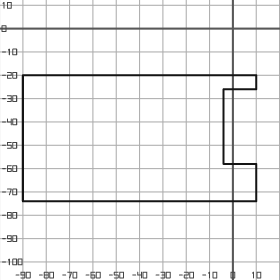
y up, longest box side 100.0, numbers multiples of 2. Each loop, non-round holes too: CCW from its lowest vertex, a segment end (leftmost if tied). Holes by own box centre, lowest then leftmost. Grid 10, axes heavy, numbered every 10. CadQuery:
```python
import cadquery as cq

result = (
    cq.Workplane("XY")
    .moveTo(-90.0, -74.0)
    .lineTo(10.0, -74.0)
    .lineTo(10.0, -58.0)
    .lineTo(-4.0, -58.0)
    .lineTo(-4.0, -26.0)
    .lineTo(10.0, -26.0)
    .lineTo(10.0, -20.0)
    .lineTo(-90.0, -20.0)
    .close()
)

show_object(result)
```